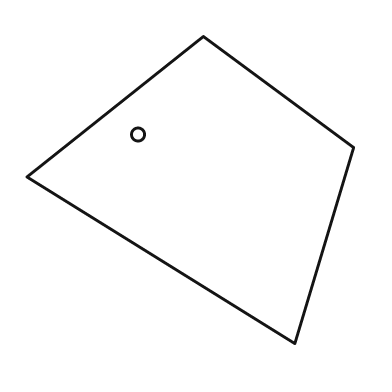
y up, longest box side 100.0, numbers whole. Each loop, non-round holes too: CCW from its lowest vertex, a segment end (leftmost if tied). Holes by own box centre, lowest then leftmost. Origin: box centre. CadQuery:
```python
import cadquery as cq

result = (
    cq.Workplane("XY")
    .moveTo(32.0, -47.0)
    .lineTo(50.0, 13.0)
    .lineTo(4.0, 47.0)
    .lineTo(-50.0, 4.0)
    .close()
    .moveTo(-16.0, 17.0)
    .circle(2.0)
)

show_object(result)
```